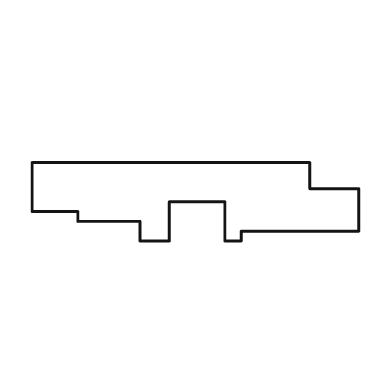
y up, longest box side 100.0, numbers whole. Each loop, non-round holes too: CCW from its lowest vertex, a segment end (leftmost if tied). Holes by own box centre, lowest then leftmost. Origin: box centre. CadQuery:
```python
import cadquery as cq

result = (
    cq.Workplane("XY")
    .moveTo(-17.0, -12.0)
    .lineTo(-8.0, -12.0)
    .lineTo(-8.0, 0.0)
    .lineTo(9.0, 0.0)
    .lineTo(9.0, -12.0)
    .lineTo(14.0, -12.0)
    .lineTo(14.0, -9.0)
    .lineTo(50.0, -9.0)
    .lineTo(50.0, 4.0)
    .lineTo(35.0, 4.0)
    .lineTo(35.0, 12.0)
    .lineTo(-50.0, 12.0)
    .lineTo(-50.0, -3.0)
    .lineTo(-36.0, -3.0)
    .lineTo(-36.0, -6.0)
    .lineTo(-17.0, -6.0)
    .close()
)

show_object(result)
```